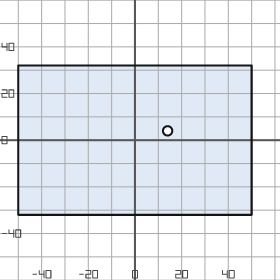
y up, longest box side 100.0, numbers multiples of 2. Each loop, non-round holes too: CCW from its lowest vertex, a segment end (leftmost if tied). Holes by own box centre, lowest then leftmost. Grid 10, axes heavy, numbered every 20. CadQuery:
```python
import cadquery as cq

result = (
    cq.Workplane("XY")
    .moveTo(-50.0, -32.0)
    .lineTo(50.0, -32.0)
    .lineTo(50.0, 32.0)
    .lineTo(-50.0, 32.0)
    .close()
    .moveTo(14.0, 4.0)
    .circle(2.0)
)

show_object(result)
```